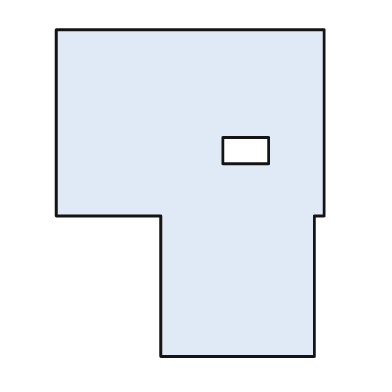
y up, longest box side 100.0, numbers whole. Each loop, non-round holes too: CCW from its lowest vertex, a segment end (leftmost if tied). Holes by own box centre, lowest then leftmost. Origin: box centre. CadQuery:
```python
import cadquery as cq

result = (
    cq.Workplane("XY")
    .moveTo(-9.0, -50.0)
    .lineTo(38.0, -50.0)
    .lineTo(38.0, -7.0)
    .lineTo(41.0, -7.0)
    .lineTo(41.0, 50.0)
    .lineTo(-41.0, 50.0)
    .lineTo(-41.0, -7.0)
    .lineTo(-9.0, -7.0)
    .close()
    .moveTo(10.0, 9.0)
    .lineTo(24.0, 9.0)
    .lineTo(24.0, 17.0)
    .lineTo(10.0, 17.0)
    .close()
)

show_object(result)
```